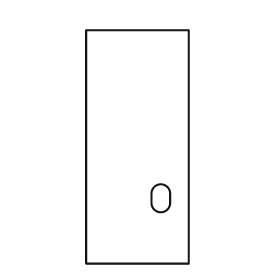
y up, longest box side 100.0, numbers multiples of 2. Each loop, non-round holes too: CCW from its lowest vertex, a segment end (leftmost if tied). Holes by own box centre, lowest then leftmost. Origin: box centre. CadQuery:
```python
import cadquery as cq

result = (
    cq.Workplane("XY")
    .moveTo(-22.0, -50.0)
    .lineTo(22.0, -50.0)
    .lineTo(22.0, 50.0)
    .lineTo(-22.0, 50.0)
    .close()
    .moveTo(6.0, -24.0)
    .threePointArc((10.0, -28.0), (14.0, -24.0))
    .lineTo(14.0, -20.0)
    .threePointArc((10.0, -16.0), (6.0, -20.0))
    .close()
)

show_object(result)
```